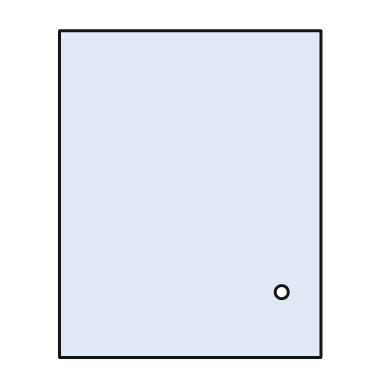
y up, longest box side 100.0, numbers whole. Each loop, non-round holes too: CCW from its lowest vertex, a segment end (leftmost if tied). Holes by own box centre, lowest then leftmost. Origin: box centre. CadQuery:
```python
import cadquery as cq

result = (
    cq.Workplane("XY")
    .moveTo(-40.0, -50.0)
    .lineTo(40.0, -50.0)
    .lineTo(40.0, 50.0)
    .lineTo(-40.0, 50.0)
    .close()
    .moveTo(28.0, -30.0)
    .circle(2.0)
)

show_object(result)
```